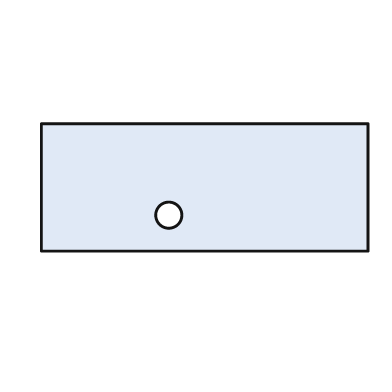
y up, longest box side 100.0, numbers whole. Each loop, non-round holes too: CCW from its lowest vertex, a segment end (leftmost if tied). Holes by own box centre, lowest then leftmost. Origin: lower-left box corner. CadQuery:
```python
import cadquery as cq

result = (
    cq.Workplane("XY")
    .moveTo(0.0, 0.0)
    .lineTo(100.0, 0.0)
    .lineTo(100.0, 39.0)
    .lineTo(0.0, 39.0)
    .close()
    .moveTo(39.0, 11.0)
    .circle(4.0)
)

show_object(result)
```